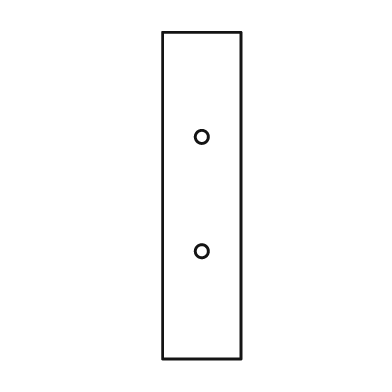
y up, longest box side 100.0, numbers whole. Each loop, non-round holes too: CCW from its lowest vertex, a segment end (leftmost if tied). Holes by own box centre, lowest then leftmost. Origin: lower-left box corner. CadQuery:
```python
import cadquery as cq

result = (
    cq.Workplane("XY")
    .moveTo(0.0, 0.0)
    .lineTo(24.0, 0.0)
    .lineTo(24.0, 100.0)
    .lineTo(0.0, 100.0)
    .close()
    .moveTo(12.0, 33.0)
    .circle(2.0)
    .moveTo(12.0, 68.0)
    .circle(2.0)
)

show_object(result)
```